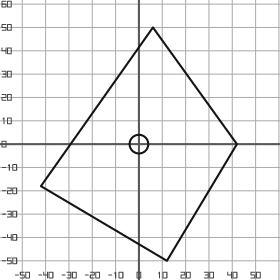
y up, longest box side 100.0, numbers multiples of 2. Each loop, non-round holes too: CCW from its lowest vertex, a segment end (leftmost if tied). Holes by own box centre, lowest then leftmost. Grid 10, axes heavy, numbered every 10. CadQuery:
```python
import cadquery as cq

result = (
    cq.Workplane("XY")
    .moveTo(12.0, -50.0)
    .lineTo(42.0, 0.0)
    .lineTo(6.0, 50.0)
    .lineTo(-42.0, -18.0)
    .close()
    .moveTo(0.0, 0.0)
    .circle(4.0)
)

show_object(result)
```